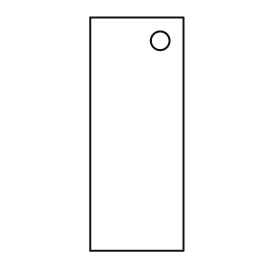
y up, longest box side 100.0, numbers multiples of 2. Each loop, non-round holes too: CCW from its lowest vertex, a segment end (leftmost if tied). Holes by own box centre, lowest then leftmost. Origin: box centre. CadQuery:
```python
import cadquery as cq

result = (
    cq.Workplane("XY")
    .moveTo(-20.0, -50.0)
    .lineTo(20.0, -50.0)
    .lineTo(20.0, 50.0)
    .lineTo(-20.0, 50.0)
    .close()
    .moveTo(10.0, 40.0)
    .circle(4.0)
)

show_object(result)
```